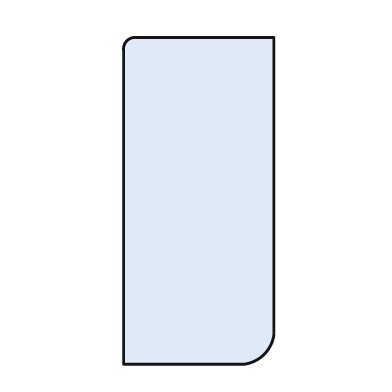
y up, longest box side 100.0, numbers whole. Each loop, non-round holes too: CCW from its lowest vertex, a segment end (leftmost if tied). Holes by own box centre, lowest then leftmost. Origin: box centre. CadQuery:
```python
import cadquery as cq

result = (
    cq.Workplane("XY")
    .moveTo(-23.0, -50.0)
    .lineTo(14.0, -50.0)
    .threePointArc((20.0, -47.0), (23.0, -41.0))
    .lineTo(23.0, 50.0)
    .lineTo(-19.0, 50.0)
    .threePointArc((-22.0, 49.0), (-23.0, 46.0))
    .close()
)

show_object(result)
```